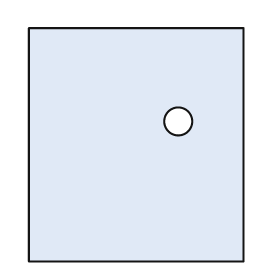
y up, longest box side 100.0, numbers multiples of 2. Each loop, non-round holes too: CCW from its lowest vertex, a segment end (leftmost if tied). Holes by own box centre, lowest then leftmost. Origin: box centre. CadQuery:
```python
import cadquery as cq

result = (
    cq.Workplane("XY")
    .moveTo(-46.0, -50.0)
    .lineTo(46.0, -50.0)
    .lineTo(46.0, 50.0)
    .lineTo(-46.0, 50.0)
    .close()
    .moveTo(18.0, 10.0)
    .circle(6.0)
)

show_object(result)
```